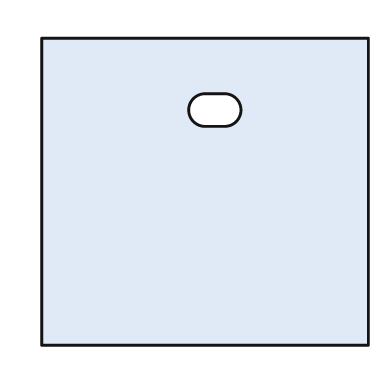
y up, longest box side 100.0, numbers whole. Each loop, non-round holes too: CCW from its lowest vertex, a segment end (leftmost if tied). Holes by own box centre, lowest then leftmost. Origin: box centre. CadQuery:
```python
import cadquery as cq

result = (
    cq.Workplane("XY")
    .moveTo(-50.0, -47.0)
    .lineTo(50.0, -47.0)
    .lineTo(50.0, 47.0)
    .lineTo(-50.0, 47.0)
    .close()
    .moveTo(0.0, 20.0)
    .lineTo(6.0, 20.0)
    .threePointArc((11.0, 25.0), (6.0, 30.0))
    .lineTo(0.0, 30.0)
    .threePointArc((-5.0, 25.0), (0.0, 20.0))
    .close()
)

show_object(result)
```